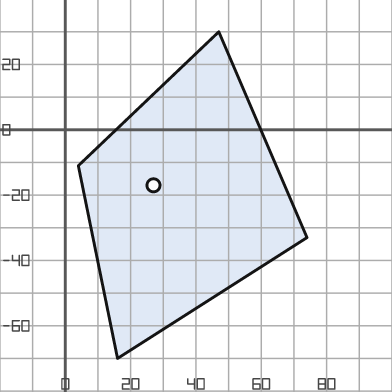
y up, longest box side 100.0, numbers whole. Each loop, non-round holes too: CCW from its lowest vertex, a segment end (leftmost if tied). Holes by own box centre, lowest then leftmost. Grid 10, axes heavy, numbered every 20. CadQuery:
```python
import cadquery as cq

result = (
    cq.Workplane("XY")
    .moveTo(16.0, -70.0)
    .lineTo(74.0, -33.0)
    .lineTo(47.0, 30.0)
    .lineTo(4.0, -11.0)
    .close()
    .moveTo(27.0, -17.0)
    .circle(2.0)
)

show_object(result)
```